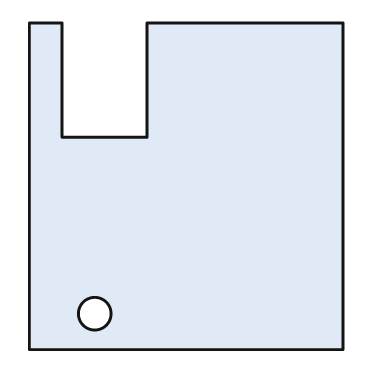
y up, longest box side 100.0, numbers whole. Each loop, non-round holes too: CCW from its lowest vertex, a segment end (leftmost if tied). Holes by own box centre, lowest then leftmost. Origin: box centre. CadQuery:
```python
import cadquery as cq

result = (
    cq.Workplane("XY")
    .moveTo(-48.0, -50.0)
    .lineTo(48.0, -50.0)
    .lineTo(48.0, 50.0)
    .lineTo(-12.0, 50.0)
    .lineTo(-12.0, 15.0)
    .lineTo(-38.0, 15.0)
    .lineTo(-38.0, 50.0)
    .lineTo(-48.0, 50.0)
    .close()
    .moveTo(-28.0, -39.0)
    .circle(5.0)
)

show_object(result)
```